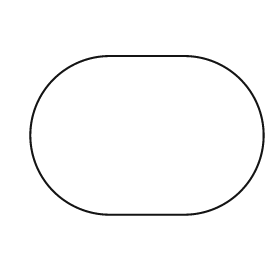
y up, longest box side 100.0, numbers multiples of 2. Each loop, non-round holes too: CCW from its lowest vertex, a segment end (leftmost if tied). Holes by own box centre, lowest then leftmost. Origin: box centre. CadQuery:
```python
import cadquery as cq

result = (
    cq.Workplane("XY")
    .moveTo(-16.0, -34.0)
    .lineTo(16.0, -34.0)
    .threePointArc((50.0, 0.0), (16.0, 34.0))
    .lineTo(-16.0, 34.0)
    .threePointArc((-50.0, 0.0), (-16.0, -34.0))
    .close()
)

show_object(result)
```